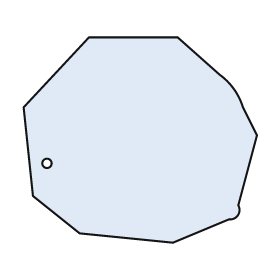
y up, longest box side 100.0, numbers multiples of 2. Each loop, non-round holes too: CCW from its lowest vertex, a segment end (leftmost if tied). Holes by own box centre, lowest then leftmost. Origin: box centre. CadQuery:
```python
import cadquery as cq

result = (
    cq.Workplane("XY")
    .moveTo(14.0, -44.0)
    .lineTo(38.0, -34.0)
    .threePointArc((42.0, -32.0), (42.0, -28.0))
    .lineTo(50.0, 2.0)
    .lineTo(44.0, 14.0)
    .threePointArc((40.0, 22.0), (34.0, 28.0))
    .lineTo(16.0, 44.0)
    .lineTo(-22.0, 44.0)
    .lineTo(-50.0, 14.0)
    .lineTo(-46.0, -24.0)
    .lineTo(-26.0, -40.0)
    .close()
    .moveTo(-40.0, -10.0)
    .circle(2.0)
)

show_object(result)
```